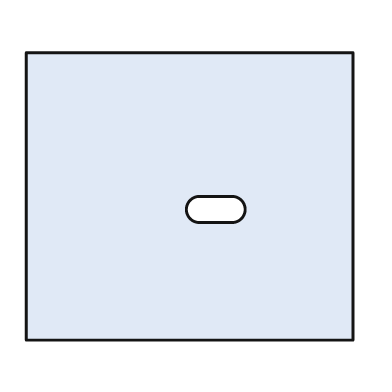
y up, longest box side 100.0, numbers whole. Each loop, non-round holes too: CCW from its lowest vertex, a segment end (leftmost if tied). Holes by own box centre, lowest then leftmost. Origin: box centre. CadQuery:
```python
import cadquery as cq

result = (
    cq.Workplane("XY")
    .moveTo(-50.0, -44.0)
    .lineTo(50.0, -44.0)
    .lineTo(50.0, 44.0)
    .lineTo(-50.0, 44.0)
    .close()
    .moveTo(3.0, -8.0)
    .lineTo(13.0, -8.0)
    .threePointArc((17.0, -4.0), (13.0, 0.0))
    .lineTo(3.0, 0.0)
    .threePointArc((-1.0, -4.0), (3.0, -8.0))
    .close()
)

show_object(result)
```